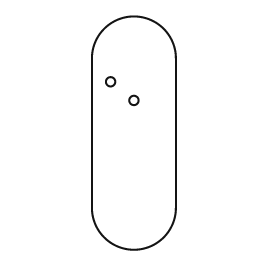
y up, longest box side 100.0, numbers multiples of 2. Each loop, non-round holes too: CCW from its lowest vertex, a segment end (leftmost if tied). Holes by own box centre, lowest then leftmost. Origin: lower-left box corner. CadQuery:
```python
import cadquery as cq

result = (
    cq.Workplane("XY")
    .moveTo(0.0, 18.0)
    .threePointArc((18.0, 0.0), (36.0, 18.0))
    .lineTo(36.0, 82.0)
    .threePointArc((18.0, 100.0), (0.0, 82.0))
    .close()
    .moveTo(18.0, 64.0)
    .circle(2.0)
    .moveTo(8.0, 72.0)
    .circle(2.0)
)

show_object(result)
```